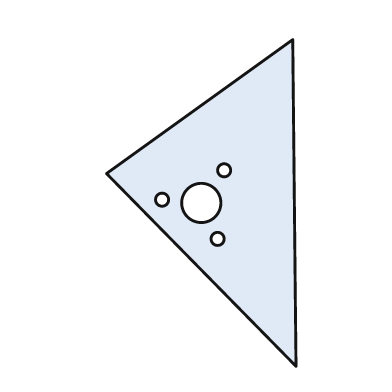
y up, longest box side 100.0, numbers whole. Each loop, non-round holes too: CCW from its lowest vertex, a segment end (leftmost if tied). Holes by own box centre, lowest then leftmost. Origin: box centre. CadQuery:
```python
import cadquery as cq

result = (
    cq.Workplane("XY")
    .moveTo(29.0, -50.0)
    .lineTo(28.0, 50.0)
    .lineTo(-29.0, 9.0)
    .close()
    .moveTo(5.0, -11.0)
    .circle(2.0)
    .moveTo(0.0, 0.0)
    .circle(6.0)
    .moveTo(-12.0, 1.0)
    .circle(2.0)
    .moveTo(7.0, 10.0)
    .circle(2.0)
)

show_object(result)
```